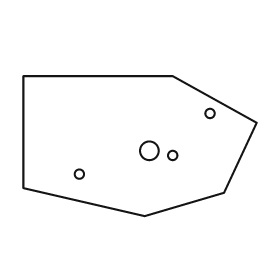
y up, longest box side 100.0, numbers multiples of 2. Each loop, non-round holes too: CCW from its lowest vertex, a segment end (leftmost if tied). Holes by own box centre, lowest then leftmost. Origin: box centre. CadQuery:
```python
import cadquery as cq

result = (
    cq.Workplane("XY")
    .moveTo(2.0, -30.0)
    .lineTo(36.0, -20.0)
    .lineTo(50.0, 10.0)
    .lineTo(14.0, 30.0)
    .lineTo(-50.0, 30.0)
    .lineTo(-50.0, -18.0)
    .close()
    .moveTo(-26.0, -12.0)
    .circle(2.0)
    .moveTo(14.0, -4.0)
    .circle(2.0)
    .moveTo(4.0, -2.0)
    .circle(4.0)
    .moveTo(30.0, 14.0)
    .circle(2.0)
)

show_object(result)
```